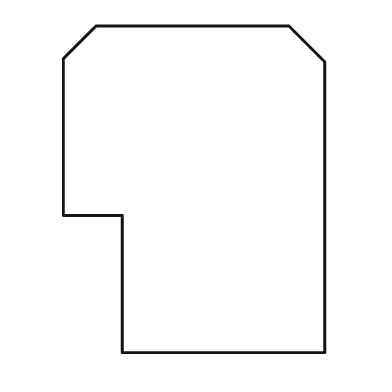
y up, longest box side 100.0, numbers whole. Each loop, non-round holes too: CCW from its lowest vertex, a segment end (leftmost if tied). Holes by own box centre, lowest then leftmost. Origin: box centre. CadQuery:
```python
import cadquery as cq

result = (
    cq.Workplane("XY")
    .moveTo(-22.0, -50.0)
    .lineTo(40.0, -50.0)
    .lineTo(40.0, 39.0)
    .lineTo(29.0, 50.0)
    .lineTo(-30.0, 50.0)
    .lineTo(-40.0, 40.0)
    .lineTo(-40.0, -8.0)
    .lineTo(-22.0, -8.0)
    .close()
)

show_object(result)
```